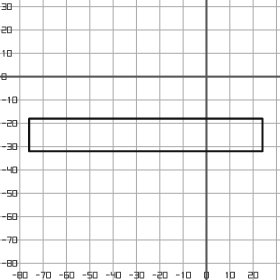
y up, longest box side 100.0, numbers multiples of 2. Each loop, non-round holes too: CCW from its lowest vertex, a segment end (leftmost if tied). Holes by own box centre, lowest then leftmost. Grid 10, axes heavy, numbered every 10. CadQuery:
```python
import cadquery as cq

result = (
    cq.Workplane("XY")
    .moveTo(-76.0, -32.0)
    .lineTo(24.0, -32.0)
    .lineTo(24.0, -18.0)
    .lineTo(-76.0, -18.0)
    .close()
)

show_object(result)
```